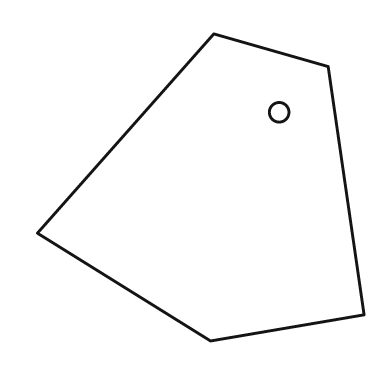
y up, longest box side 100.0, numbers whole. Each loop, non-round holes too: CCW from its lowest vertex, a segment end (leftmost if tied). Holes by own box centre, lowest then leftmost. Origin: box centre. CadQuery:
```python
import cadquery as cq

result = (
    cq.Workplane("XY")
    .moveTo(3.0, -47.0)
    .lineTo(50.0, -39.0)
    .lineTo(39.0, 37.0)
    .lineTo(4.0, 47.0)
    .lineTo(-50.0, -14.0)
    .close()
    .moveTo(24.0, 23.0)
    .circle(3.0)
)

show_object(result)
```